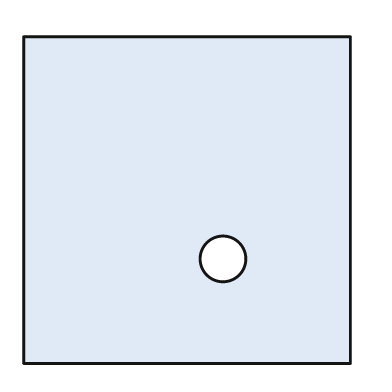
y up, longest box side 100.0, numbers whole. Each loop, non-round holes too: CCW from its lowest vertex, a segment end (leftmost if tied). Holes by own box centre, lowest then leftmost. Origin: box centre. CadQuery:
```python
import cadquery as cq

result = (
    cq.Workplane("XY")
    .moveTo(-50.0, -50.0)
    .lineTo(50.0, -50.0)
    .lineTo(50.0, 50.0)
    .lineTo(-50.0, 50.0)
    .close()
    .moveTo(11.0, -18.0)
    .circle(7.0)
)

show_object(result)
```